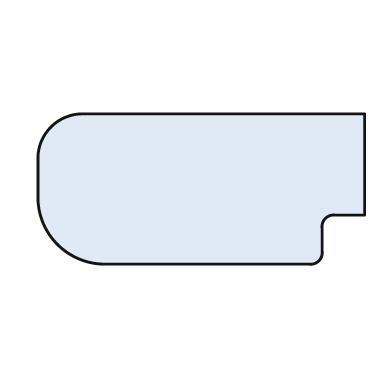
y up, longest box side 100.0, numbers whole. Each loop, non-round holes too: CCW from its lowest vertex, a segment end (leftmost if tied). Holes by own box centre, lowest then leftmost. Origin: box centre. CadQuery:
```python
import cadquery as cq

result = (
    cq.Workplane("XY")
    .moveTo(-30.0, -23.0)
    .lineTo(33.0, -23.0)
    .threePointArc((36.0, -22.0), (37.0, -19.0))
    .lineTo(37.0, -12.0)
    .threePointArc((38.0, -9.0), (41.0, -8.0))
    .lineTo(50.0, -8.0)
    .lineTo(50.0, 23.0)
    .lineTo(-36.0, 23.0)
    .threePointArc((-46.0, 19.0), (-50.0, 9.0))
    .lineTo(-50.0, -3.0)
    .threePointArc((-44.0, -17.0), (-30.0, -23.0))
    .close()
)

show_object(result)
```